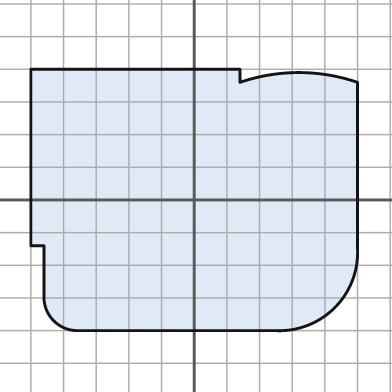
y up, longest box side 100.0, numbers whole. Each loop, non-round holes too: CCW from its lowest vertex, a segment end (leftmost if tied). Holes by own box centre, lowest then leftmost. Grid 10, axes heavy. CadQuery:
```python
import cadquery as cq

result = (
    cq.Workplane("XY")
    .moveTo(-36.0, -40.0)
    .lineTo(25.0, -40.0)
    .threePointArc((43.0, -33.0), (50.0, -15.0))
    .lineTo(50.0, 36.0)
    .threePointArc((32.0, 39.0), (14.0, 36.0))
    .lineTo(14.0, 40.0)
    .lineTo(-50.0, 40.0)
    .lineTo(-50.0, -14.0)
    .lineTo(-46.0, -14.0)
    .lineTo(-46.0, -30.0)
    .threePointArc((-43.0, -37.0), (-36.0, -40.0))
    .close()
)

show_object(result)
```